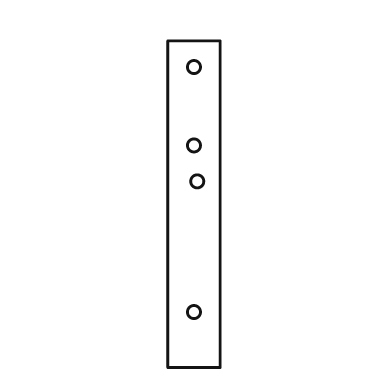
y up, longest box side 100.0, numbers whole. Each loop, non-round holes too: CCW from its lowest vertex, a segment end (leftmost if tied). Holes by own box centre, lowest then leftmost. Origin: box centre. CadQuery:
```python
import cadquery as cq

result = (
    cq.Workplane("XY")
    .moveTo(-8.0, -50.0)
    .lineTo(8.0, -50.0)
    .lineTo(8.0, 50.0)
    .lineTo(-8.0, 50.0)
    .close()
    .moveTo(0.0, -33.0)
    .circle(2.0)
    .moveTo(1.0, 7.0)
    .circle(2.0)
    .moveTo(0.0, 18.0)
    .circle(2.0)
    .moveTo(0.0, 42.0)
    .circle(2.0)
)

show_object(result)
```